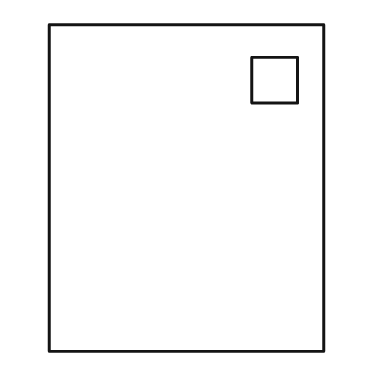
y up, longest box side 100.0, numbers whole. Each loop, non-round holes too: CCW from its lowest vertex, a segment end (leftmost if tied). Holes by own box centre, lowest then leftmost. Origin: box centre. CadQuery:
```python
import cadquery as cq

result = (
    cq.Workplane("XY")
    .moveTo(-42.0, -50.0)
    .lineTo(42.0, -50.0)
    .lineTo(42.0, 50.0)
    .lineTo(-42.0, 50.0)
    .close()
    .moveTo(20.0, 26.0)
    .lineTo(34.0, 26.0)
    .lineTo(34.0, 40.0)
    .lineTo(20.0, 40.0)
    .close()
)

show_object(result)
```